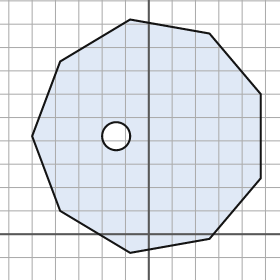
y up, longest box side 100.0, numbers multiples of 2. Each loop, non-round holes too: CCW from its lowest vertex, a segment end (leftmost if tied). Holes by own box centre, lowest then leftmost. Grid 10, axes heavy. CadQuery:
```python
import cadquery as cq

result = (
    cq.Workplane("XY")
    .moveTo(-8.0, -8.0)
    .lineTo(26.0, -2.0)
    .lineTo(48.0, 24.0)
    .lineTo(48.0, 60.0)
    .lineTo(26.0, 86.0)
    .lineTo(-8.0, 92.0)
    .lineTo(-38.0, 74.0)
    .lineTo(-50.0, 42.0)
    .lineTo(-38.0, 10.0)
    .close()
    .moveTo(-14.0, 42.0)
    .circle(6.0)
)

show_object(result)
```